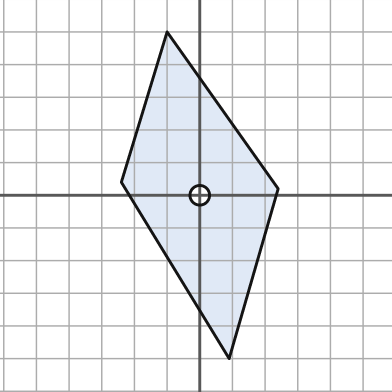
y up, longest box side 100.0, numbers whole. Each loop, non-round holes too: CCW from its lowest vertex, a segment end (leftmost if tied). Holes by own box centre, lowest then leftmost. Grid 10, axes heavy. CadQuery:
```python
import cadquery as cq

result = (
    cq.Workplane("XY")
    .moveTo(9.0, -50.0)
    .lineTo(24.0, 2.0)
    .lineTo(-10.0, 50.0)
    .lineTo(-24.0, 4.0)
    .close()
    .moveTo(0.0, 0.0)
    .circle(3.0)
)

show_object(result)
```